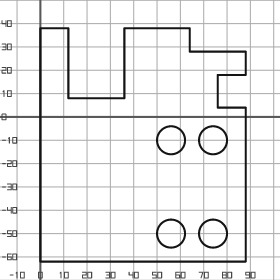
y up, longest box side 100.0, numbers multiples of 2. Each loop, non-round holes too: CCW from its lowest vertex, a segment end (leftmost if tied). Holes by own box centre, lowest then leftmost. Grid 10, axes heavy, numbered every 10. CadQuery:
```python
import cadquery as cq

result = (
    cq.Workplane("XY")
    .moveTo(0.0, -62.0)
    .lineTo(88.0, -62.0)
    .lineTo(88.0, 4.0)
    .lineTo(76.0, 4.0)
    .lineTo(76.0, 18.0)
    .lineTo(88.0, 18.0)
    .lineTo(88.0, 28.0)
    .lineTo(64.0, 28.0)
    .lineTo(64.0, 38.0)
    .lineTo(36.0, 38.0)
    .lineTo(36.0, 8.0)
    .lineTo(12.0, 8.0)
    .lineTo(12.0, 38.0)
    .lineTo(0.0, 38.0)
    .close()
    .moveTo(56.0, -50.0)
    .circle(6.0)
    .moveTo(74.0, -50.0)
    .circle(6.0)
    .moveTo(56.0, -10.0)
    .circle(6.0)
    .moveTo(74.0, -10.0)
    .circle(6.0)
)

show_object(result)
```